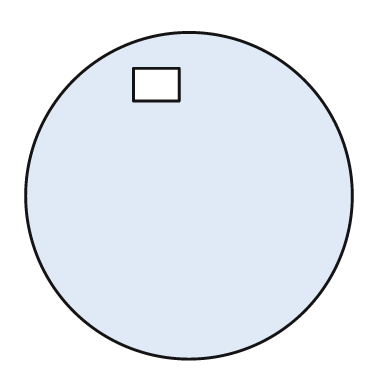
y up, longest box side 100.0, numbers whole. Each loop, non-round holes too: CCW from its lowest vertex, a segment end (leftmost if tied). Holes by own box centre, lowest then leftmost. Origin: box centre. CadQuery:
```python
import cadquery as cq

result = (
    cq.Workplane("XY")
    .moveTo(0.0, 0.0)
    .circle(50.0)
    .moveTo(-17.0, 29.0)
    .lineTo(-3.0, 29.0)
    .lineTo(-3.0, 39.0)
    .lineTo(-17.0, 39.0)
    .close()
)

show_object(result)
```